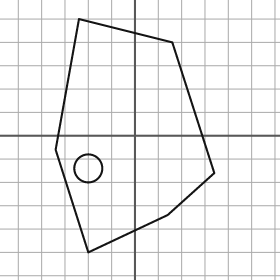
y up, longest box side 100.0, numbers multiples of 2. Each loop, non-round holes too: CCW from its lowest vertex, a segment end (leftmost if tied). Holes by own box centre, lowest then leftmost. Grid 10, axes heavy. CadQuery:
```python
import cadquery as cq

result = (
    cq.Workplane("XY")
    .moveTo(-20.0, -50.0)
    .lineTo(14.0, -34.0)
    .lineTo(34.0, -16.0)
    .lineTo(16.0, 40.0)
    .lineTo(-24.0, 50.0)
    .lineTo(-34.0, -6.0)
    .close()
    .moveTo(-20.0, -14.0)
    .circle(6.0)
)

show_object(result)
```